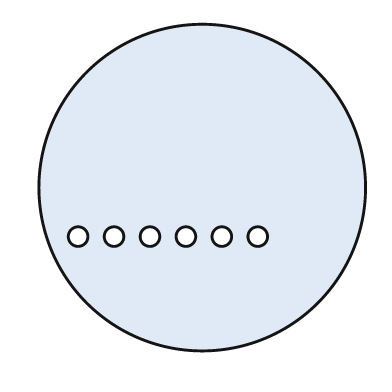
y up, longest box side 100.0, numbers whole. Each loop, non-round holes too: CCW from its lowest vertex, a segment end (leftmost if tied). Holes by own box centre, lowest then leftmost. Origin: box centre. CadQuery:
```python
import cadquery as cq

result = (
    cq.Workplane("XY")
    .moveTo(0.0, 0.0)
    .circle(50.0)
    .moveTo(-38.0, -15.0)
    .circle(3.0)
    .moveTo(-27.0, -15.0)
    .circle(3.0)
    .moveTo(-16.0, -15.0)
    .circle(3.0)
    .moveTo(-5.0, -15.0)
    .circle(3.0)
    .moveTo(6.0, -15.0)
    .circle(3.0)
    .moveTo(17.0, -15.0)
    .circle(3.0)
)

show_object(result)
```